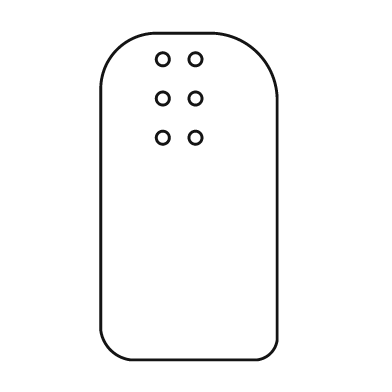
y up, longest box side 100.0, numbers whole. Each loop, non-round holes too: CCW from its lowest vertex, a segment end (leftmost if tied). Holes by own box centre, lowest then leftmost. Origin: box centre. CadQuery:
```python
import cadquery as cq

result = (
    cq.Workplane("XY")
    .moveTo(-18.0, -50.0)
    .lineTo(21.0, -50.0)
    .threePointArc((25.0, -48.0), (27.0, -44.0))
    .lineTo(27.0, 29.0)
    .threePointArc((21.0, 44.0), (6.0, 50.0))
    .lineTo(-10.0, 50.0)
    .threePointArc((-22.0, 45.0), (-27.0, 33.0))
    .lineTo(-27.0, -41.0)
    .threePointArc((-24.0, -47.0), (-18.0, -50.0))
    .close()
    .moveTo(-8.0, 18.0)
    .circle(2.0)
    .moveTo(2.0, 18.0)
    .circle(2.0)
    .moveTo(-8.0, 30.0)
    .circle(2.0)
    .moveTo(2.0, 30.0)
    .circle(2.0)
    .moveTo(-8.0, 42.0)
    .circle(2.0)
    .moveTo(2.0, 42.0)
    .circle(2.0)
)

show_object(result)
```